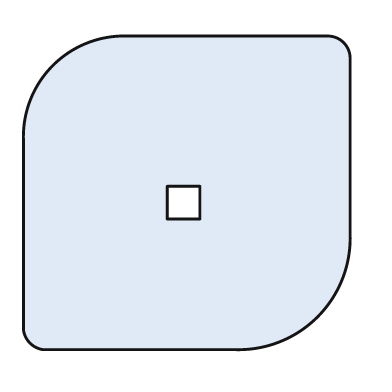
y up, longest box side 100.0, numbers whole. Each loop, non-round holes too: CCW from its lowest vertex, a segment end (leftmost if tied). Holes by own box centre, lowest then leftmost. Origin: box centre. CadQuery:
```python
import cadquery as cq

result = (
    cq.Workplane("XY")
    .moveTo(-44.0, -48.0)
    .lineTo(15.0, -48.0)
    .threePointArc((40.0, -38.0), (50.0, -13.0))
    .lineTo(50.0, 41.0)
    .threePointArc((48.0, 46.0), (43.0, 48.0))
    .lineTo(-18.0, 48.0)
    .threePointArc((-41.0, 39.0), (-50.0, 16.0))
    .lineTo(-50.0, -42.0)
    .threePointArc((-48.0, -46.0), (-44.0, -48.0))
    .close()
    .moveTo(-6.0, -8.0)
    .lineTo(4.0, -8.0)
    .lineTo(4.0, 2.0)
    .lineTo(-6.0, 2.0)
    .close()
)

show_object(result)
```